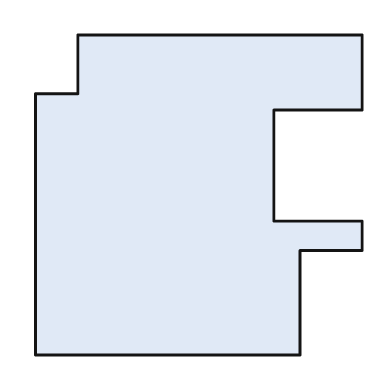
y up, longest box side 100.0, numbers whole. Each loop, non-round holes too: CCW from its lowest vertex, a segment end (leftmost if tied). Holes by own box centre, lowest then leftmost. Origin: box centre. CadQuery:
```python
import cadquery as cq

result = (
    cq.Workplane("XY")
    .moveTo(-50.0, -49.0)
    .lineTo(31.0, -49.0)
    .lineTo(31.0, -17.0)
    .lineTo(50.0, -17.0)
    .lineTo(50.0, -8.0)
    .lineTo(23.0, -8.0)
    .lineTo(23.0, 26.0)
    .lineTo(50.0, 26.0)
    .lineTo(50.0, 49.0)
    .lineTo(-37.0, 49.0)
    .lineTo(-37.0, 31.0)
    .lineTo(-50.0, 31.0)
    .close()
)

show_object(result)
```